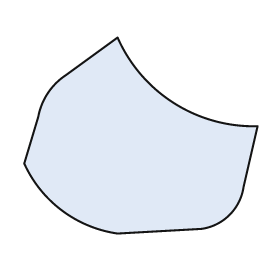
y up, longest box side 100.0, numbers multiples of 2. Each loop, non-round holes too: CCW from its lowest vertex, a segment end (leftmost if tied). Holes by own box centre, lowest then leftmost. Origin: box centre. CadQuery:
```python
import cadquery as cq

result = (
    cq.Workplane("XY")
    .moveTo(-10.0, -42.0)
    .lineTo(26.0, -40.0)
    .threePointArc((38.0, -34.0), (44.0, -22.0))
    .lineTo(50.0, 4.0)
    .threePointArc((14.0, 14.0), (-10.0, 42.0))
    .lineTo(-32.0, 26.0)
    .threePointArc((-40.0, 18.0), (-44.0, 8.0))
    .lineTo(-50.0, -12.0)
    .threePointArc((-34.0, -32.0), (-10.0, -42.0))
    .close()
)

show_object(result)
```